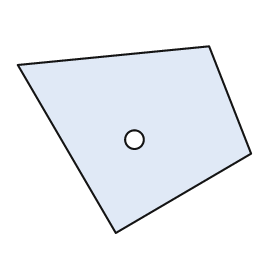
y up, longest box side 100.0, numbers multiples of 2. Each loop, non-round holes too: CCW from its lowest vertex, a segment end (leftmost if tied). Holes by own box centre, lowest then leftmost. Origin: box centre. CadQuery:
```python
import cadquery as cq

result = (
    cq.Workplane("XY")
    .moveTo(-8.0, -40.0)
    .lineTo(50.0, -6.0)
    .lineTo(32.0, 40.0)
    .lineTo(-50.0, 32.0)
    .close()
    .moveTo(0.0, 0.0)
    .circle(4.0)
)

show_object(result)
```